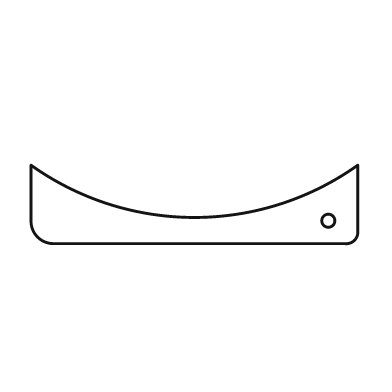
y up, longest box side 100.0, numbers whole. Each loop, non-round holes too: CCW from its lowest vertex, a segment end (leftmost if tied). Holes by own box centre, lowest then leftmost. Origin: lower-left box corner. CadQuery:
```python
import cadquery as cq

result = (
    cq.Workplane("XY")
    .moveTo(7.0, 0.0)
    .lineTo(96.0, 0.0)
    .threePointArc((99.0, 1.0), (100.0, 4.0))
    .lineTo(100.0, 24.0)
    .threePointArc((50.0, 8.0), (0.0, 24.0))
    .lineTo(0.0, 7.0)
    .threePointArc((2.0, 2.0), (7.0, 0.0))
    .close()
    .moveTo(91.0, 7.0)
    .circle(2.0)
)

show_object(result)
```